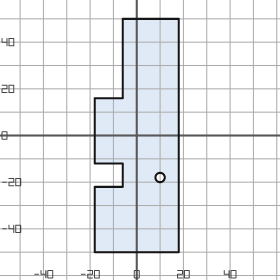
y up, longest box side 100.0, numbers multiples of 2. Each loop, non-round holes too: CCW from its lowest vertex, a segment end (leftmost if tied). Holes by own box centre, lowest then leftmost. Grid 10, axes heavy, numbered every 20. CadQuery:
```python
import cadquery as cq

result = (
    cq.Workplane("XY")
    .moveTo(-18.0, -50.0)
    .lineTo(18.0, -50.0)
    .lineTo(18.0, 50.0)
    .lineTo(-6.0, 50.0)
    .lineTo(-6.0, 16.0)
    .lineTo(-18.0, 16.0)
    .lineTo(-18.0, -12.0)
    .lineTo(-6.0, -12.0)
    .lineTo(-6.0, -22.0)
    .lineTo(-18.0, -22.0)
    .close()
    .moveTo(10.0, -18.0)
    .circle(2.0)
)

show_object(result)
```